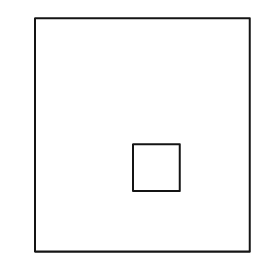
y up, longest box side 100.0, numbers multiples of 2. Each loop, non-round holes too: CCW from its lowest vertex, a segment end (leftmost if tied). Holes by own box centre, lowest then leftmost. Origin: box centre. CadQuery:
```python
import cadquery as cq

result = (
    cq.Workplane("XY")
    .moveTo(-46.0, -50.0)
    .lineTo(46.0, -50.0)
    .lineTo(46.0, 50.0)
    .lineTo(-46.0, 50.0)
    .close()
    .moveTo(-4.0, -24.0)
    .lineTo(16.0, -24.0)
    .lineTo(16.0, -4.0)
    .lineTo(-4.0, -4.0)
    .close()
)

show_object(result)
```